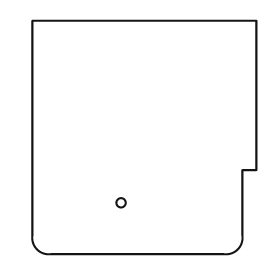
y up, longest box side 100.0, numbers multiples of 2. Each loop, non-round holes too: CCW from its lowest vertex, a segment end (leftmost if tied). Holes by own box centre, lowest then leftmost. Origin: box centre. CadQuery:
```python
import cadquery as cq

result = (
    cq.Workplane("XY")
    .moveTo(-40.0, -50.0)
    .lineTo(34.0, -50.0)
    .threePointArc((40.0, -48.0), (42.0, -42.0))
    .lineTo(42.0, -14.0)
    .lineTo(48.0, -14.0)
    .lineTo(48.0, 50.0)
    .lineTo(-48.0, 50.0)
    .lineTo(-48.0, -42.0)
    .threePointArc((-46.0, -48.0), (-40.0, -50.0))
    .close()
    .moveTo(-10.0, -28.0)
    .circle(2.0)
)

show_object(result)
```